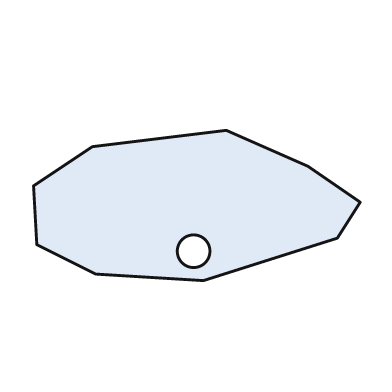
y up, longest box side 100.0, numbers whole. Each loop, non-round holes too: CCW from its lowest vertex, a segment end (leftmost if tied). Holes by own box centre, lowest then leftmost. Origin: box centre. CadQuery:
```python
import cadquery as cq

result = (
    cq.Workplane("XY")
    .moveTo(2.0, -23.0)
    .lineTo(43.0, -10.0)
    .lineTo(50.0, 1.0)
    .lineTo(34.0, 12.0)
    .lineTo(9.0, 23.0)
    .lineTo(-32.0, 18.0)
    .lineTo(-50.0, 6.0)
    .lineTo(-49.0, -12.0)
    .lineTo(-31.0, -21.0)
    .close()
    .moveTo(-1.0, -14.0)
    .circle(5.0)
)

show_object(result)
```